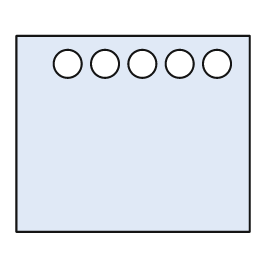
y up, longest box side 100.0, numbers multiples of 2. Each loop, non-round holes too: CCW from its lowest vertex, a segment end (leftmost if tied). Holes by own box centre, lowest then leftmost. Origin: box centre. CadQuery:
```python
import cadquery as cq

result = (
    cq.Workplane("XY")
    .moveTo(-50.0, -42.0)
    .lineTo(50.0, -42.0)
    .lineTo(50.0, 42.0)
    .lineTo(-50.0, 42.0)
    .close()
    .moveTo(-28.0, 30.0)
    .circle(6.0)
    .moveTo(-12.0, 30.0)
    .circle(6.0)
    .moveTo(4.0, 30.0)
    .circle(6.0)
    .moveTo(20.0, 30.0)
    .circle(6.0)
    .moveTo(36.0, 30.0)
    .circle(6.0)
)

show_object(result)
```